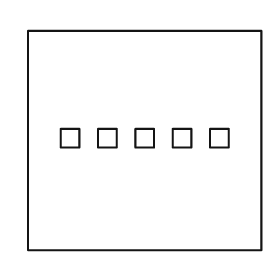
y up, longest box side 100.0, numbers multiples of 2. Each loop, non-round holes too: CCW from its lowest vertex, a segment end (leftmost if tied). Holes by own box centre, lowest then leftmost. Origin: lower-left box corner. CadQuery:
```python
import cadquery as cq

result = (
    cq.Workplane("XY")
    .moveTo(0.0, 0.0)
    .lineTo(100.0, 0.0)
    .lineTo(100.0, 94.0)
    .lineTo(0.0, 94.0)
    .close()
    .moveTo(14.0, 44.0)
    .lineTo(22.0, 44.0)
    .lineTo(22.0, 52.0)
    .lineTo(14.0, 52.0)
    .close()
    .moveTo(30.0, 44.0)
    .lineTo(38.0, 44.0)
    .lineTo(38.0, 52.0)
    .lineTo(30.0, 52.0)
    .close()
    .moveTo(46.0, 44.0)
    .lineTo(54.0, 44.0)
    .lineTo(54.0, 52.0)
    .lineTo(46.0, 52.0)
    .close()
    .moveTo(62.0, 44.0)
    .lineTo(70.0, 44.0)
    .lineTo(70.0, 52.0)
    .lineTo(62.0, 52.0)
    .close()
    .moveTo(78.0, 44.0)
    .lineTo(86.0, 44.0)
    .lineTo(86.0, 52.0)
    .lineTo(78.0, 52.0)
    .close()
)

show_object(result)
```